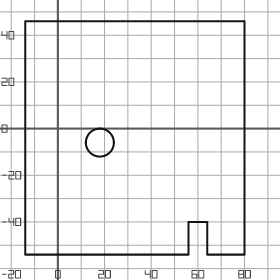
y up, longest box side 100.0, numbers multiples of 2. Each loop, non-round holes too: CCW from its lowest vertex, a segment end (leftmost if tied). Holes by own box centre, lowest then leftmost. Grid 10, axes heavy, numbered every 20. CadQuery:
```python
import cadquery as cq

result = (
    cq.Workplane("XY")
    .moveTo(-14.0, -54.0)
    .lineTo(56.0, -54.0)
    .lineTo(56.0, -40.0)
    .lineTo(64.0, -40.0)
    .lineTo(64.0, -54.0)
    .lineTo(80.0, -54.0)
    .lineTo(80.0, 46.0)
    .lineTo(-14.0, 46.0)
    .close()
    .moveTo(18.0, -6.0)
    .circle(6.0)
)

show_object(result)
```